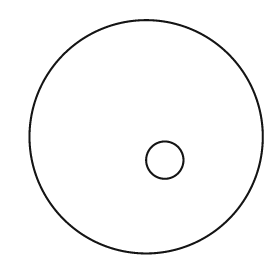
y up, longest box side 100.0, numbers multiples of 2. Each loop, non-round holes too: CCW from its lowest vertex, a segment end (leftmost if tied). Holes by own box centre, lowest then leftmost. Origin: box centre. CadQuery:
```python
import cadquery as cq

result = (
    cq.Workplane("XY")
    .moveTo(0.0, 0.0)
    .circle(50.0)
    .moveTo(8.0, -10.0)
    .circle(8.0)
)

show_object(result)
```